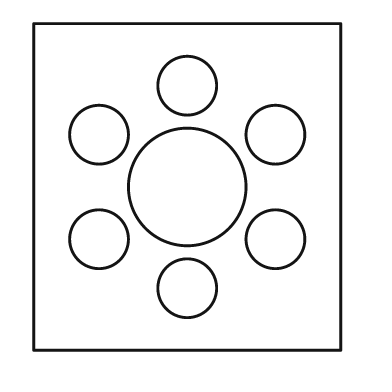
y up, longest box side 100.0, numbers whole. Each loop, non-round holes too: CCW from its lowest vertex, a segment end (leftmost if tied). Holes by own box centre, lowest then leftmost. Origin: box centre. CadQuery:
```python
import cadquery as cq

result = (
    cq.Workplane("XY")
    .moveTo(-47.0, -50.0)
    .lineTo(47.0, -50.0)
    .lineTo(47.0, 50.0)
    .lineTo(-47.0, 50.0)
    .close()
    .moveTo(0.0, -31.0)
    .circle(9.0)
    .moveTo(-27.0, -16.0)
    .circle(9.0)
    .moveTo(27.0, -16.0)
    .circle(9.0)
    .moveTo(0.0, 0.0)
    .circle(18.0)
    .moveTo(-27.0, 16.0)
    .circle(9.0)
    .moveTo(27.0, 16.0)
    .circle(9.0)
    .moveTo(0.0, 31.0)
    .circle(9.0)
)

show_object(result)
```